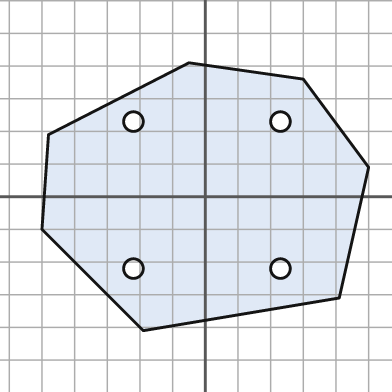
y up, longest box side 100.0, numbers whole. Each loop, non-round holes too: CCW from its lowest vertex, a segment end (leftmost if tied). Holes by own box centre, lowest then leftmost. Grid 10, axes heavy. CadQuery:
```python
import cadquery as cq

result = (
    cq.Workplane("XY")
    .moveTo(-19.0, -41.0)
    .lineTo(41.0, -31.0)
    .lineTo(50.0, 9.0)
    .lineTo(30.0, 36.0)
    .lineTo(-5.0, 41.0)
    .lineTo(-48.0, 19.0)
    .lineTo(-50.0, -10.0)
    .close()
    .moveTo(-22.0, -22.0)
    .circle(3.0)
    .moveTo(23.0, -22.0)
    .circle(3.0)
    .moveTo(-22.0, 23.0)
    .circle(3.0)
    .moveTo(23.0, 23.0)
    .circle(3.0)
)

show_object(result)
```